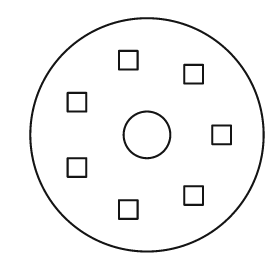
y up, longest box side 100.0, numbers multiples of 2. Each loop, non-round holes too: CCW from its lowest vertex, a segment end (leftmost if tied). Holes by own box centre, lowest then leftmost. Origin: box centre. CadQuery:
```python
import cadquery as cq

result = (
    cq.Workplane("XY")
    .moveTo(0.0, 0.0)
    .circle(50.0)
    .moveTo(-12.0, -36.0)
    .lineTo(-4.0, -36.0)
    .lineTo(-4.0, -28.0)
    .lineTo(-12.0, -28.0)
    .close()
    .moveTo(16.0, -30.0)
    .lineTo(24.0, -30.0)
    .lineTo(24.0, -22.0)
    .lineTo(16.0, -22.0)
    .close()
    .moveTo(-34.0, -18.0)
    .lineTo(-26.0, -18.0)
    .lineTo(-26.0, -10.0)
    .lineTo(-34.0, -10.0)
    .close()
    .moveTo(0.0, 0.0)
    .circle(10.0)
    .moveTo(28.0, -4.0)
    .lineTo(36.0, -4.0)
    .lineTo(36.0, 4.0)
    .lineTo(28.0, 4.0)
    .close()
    .moveTo(-34.0, 10.0)
    .lineTo(-26.0, 10.0)
    .lineTo(-26.0, 18.0)
    .lineTo(-34.0, 18.0)
    .close()
    .moveTo(16.0, 22.0)
    .lineTo(24.0, 22.0)
    .lineTo(24.0, 30.0)
    .lineTo(16.0, 30.0)
    .close()
    .moveTo(-12.0, 28.0)
    .lineTo(-4.0, 28.0)
    .lineTo(-4.0, 36.0)
    .lineTo(-12.0, 36.0)
    .close()
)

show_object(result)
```